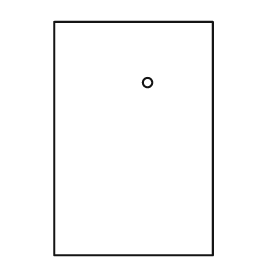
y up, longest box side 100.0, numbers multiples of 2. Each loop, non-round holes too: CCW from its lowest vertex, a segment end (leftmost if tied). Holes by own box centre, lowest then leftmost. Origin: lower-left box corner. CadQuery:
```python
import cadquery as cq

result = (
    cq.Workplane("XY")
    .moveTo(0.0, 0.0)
    .lineTo(68.0, 0.0)
    .lineTo(68.0, 100.0)
    .lineTo(0.0, 100.0)
    .close()
    .moveTo(40.0, 74.0)
    .circle(2.0)
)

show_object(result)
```